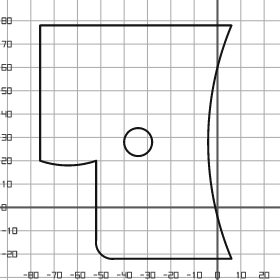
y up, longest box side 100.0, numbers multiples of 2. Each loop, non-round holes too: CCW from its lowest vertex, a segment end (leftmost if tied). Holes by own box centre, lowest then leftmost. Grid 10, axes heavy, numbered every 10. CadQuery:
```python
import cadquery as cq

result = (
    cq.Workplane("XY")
    .moveTo(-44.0, -22.0)
    .lineTo(6.0, -22.0)
    .threePointArc((-4.0, 28.0), (6.0, 78.0))
    .lineTo(-76.0, 78.0)
    .lineTo(-76.0, 20.0)
    .threePointArc((-64.0, 18.0), (-52.0, 20.0))
    .lineTo(-52.0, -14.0)
    .threePointArc((-50.0, -20.0), (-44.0, -22.0))
    .close()
    .moveTo(-34.0, 28.0)
    .circle(6.0)
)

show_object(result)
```